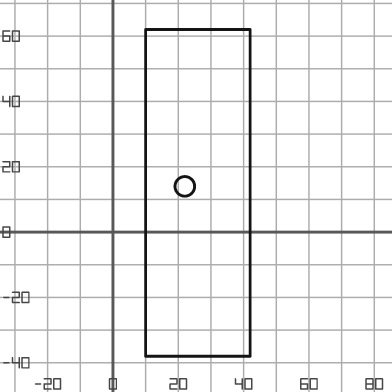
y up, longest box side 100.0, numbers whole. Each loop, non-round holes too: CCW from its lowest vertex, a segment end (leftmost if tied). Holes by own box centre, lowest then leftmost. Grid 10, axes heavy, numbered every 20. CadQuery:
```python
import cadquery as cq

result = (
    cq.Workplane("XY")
    .moveTo(10.0, -38.0)
    .lineTo(42.0, -38.0)
    .lineTo(42.0, 62.0)
    .lineTo(10.0, 62.0)
    .close()
    .moveTo(22.0, 14.0)
    .circle(3.0)
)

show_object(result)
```